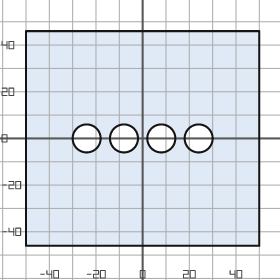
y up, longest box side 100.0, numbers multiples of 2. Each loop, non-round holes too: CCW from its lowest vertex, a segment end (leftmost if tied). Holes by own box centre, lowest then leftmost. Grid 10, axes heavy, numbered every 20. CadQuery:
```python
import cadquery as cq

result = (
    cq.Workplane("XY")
    .moveTo(-50.0, -46.0)
    .lineTo(50.0, -46.0)
    .lineTo(50.0, 46.0)
    .lineTo(-50.0, 46.0)
    .close()
    .moveTo(-24.0, 0.0)
    .circle(6.0)
    .moveTo(-8.0, 0.0)
    .circle(6.0)
    .moveTo(8.0, 0.0)
    .circle(6.0)
    .moveTo(24.0, 0.0)
    .circle(6.0)
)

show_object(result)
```